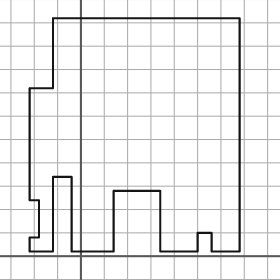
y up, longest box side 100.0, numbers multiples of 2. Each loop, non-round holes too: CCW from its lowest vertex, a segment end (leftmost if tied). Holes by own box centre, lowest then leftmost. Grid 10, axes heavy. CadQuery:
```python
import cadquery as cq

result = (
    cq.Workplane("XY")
    .moveTo(-22.0, 2.0)
    .lineTo(-12.0, 2.0)
    .lineTo(-12.0, 34.0)
    .lineTo(-4.0, 34.0)
    .lineTo(-4.0, 2.0)
    .lineTo(14.0, 2.0)
    .lineTo(14.0, 28.0)
    .lineTo(34.0, 28.0)
    .lineTo(34.0, 2.0)
    .lineTo(50.0, 2.0)
    .lineTo(50.0, 10.0)
    .lineTo(56.0, 10.0)
    .lineTo(56.0, 2.0)
    .lineTo(68.0, 2.0)
    .lineTo(68.0, 102.0)
    .lineTo(-12.0, 102.0)
    .lineTo(-12.0, 72.0)
    .lineTo(-22.0, 72.0)
    .lineTo(-22.0, 24.0)
    .lineTo(-18.0, 24.0)
    .lineTo(-18.0, 8.0)
    .lineTo(-22.0, 8.0)
    .close()
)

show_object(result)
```